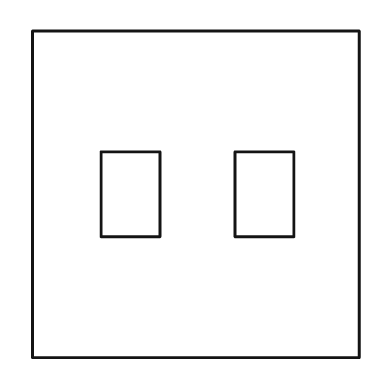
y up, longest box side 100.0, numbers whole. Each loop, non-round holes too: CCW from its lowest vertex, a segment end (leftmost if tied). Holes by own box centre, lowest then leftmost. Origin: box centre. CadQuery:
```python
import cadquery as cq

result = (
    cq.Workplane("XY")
    .moveTo(-50.0, -50.0)
    .lineTo(50.0, -50.0)
    .lineTo(50.0, 50.0)
    .lineTo(-50.0, 50.0)
    .close()
    .moveTo(-29.0, -13.0)
    .lineTo(-11.0, -13.0)
    .lineTo(-11.0, 13.0)
    .lineTo(-29.0, 13.0)
    .close()
    .moveTo(12.0, -13.0)
    .lineTo(30.0, -13.0)
    .lineTo(30.0, 13.0)
    .lineTo(12.0, 13.0)
    .close()
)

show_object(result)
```